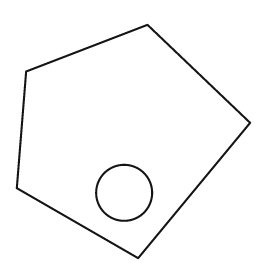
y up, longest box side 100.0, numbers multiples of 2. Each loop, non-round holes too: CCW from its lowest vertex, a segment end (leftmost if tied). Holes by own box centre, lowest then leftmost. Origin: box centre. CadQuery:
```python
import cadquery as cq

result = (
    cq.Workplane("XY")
    .moveTo(2.0, -50.0)
    .lineTo(50.0, 8.0)
    .lineTo(6.0, 50.0)
    .lineTo(-46.0, 30.0)
    .lineTo(-50.0, -20.0)
    .close()
    .moveTo(-4.0, -22.0)
    .circle(12.0)
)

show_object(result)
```